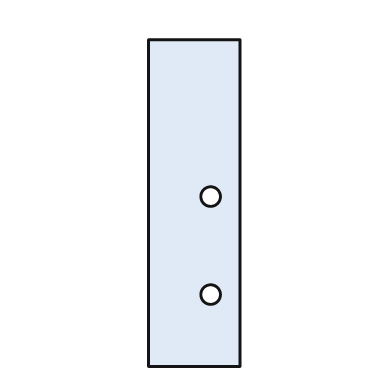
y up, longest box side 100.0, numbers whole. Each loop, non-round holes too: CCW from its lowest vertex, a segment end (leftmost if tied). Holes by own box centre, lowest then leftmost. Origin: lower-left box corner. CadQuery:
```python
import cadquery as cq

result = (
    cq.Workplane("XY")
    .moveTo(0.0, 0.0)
    .lineTo(28.0, 0.0)
    .lineTo(28.0, 100.0)
    .lineTo(0.0, 100.0)
    .close()
    .moveTo(19.0, 22.0)
    .circle(3.0)
    .moveTo(19.0, 52.0)
    .circle(3.0)
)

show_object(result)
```